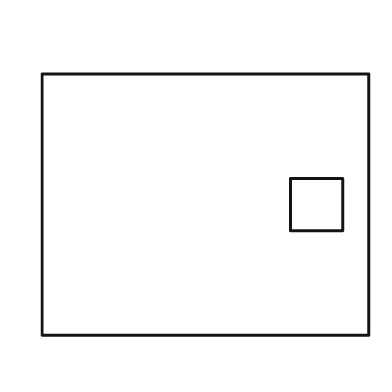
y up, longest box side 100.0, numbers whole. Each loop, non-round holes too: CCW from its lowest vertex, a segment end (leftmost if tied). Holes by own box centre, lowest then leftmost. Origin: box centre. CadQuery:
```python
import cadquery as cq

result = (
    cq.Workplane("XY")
    .moveTo(-50.0, -40.0)
    .lineTo(50.0, -40.0)
    .lineTo(50.0, 40.0)
    .lineTo(-50.0, 40.0)
    .close()
    .moveTo(26.0, -8.0)
    .lineTo(42.0, -8.0)
    .lineTo(42.0, 8.0)
    .lineTo(26.0, 8.0)
    .close()
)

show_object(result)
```